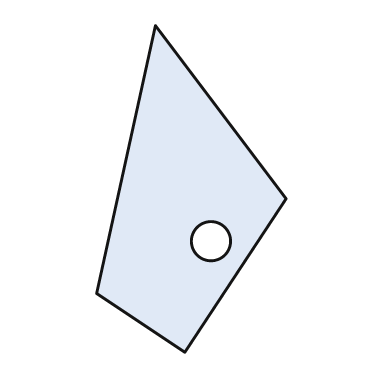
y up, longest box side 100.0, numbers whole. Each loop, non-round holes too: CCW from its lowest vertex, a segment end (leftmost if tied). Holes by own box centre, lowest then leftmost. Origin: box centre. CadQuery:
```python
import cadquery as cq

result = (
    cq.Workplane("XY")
    .moveTo(-2.0, -50.0)
    .lineTo(29.0, -3.0)
    .lineTo(-11.0, 50.0)
    .lineTo(-29.0, -32.0)
    .close()
    .moveTo(6.0, -16.0)
    .circle(6.0)
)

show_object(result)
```